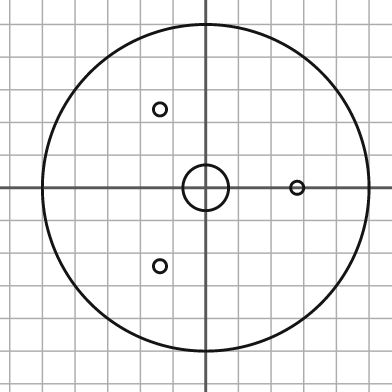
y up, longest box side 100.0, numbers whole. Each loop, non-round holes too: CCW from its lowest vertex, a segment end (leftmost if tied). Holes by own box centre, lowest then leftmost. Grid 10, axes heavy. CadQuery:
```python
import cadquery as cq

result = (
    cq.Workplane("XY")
    .moveTo(0.0, 0.0)
    .circle(50.0)
    .moveTo(-14.0, -24.0)
    .circle(2.0)
    .moveTo(0.0, 0.0)
    .circle(7.0)
    .moveTo(28.0, 0.0)
    .circle(2.0)
    .moveTo(-14.0, 24.0)
    .circle(2.0)
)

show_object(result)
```